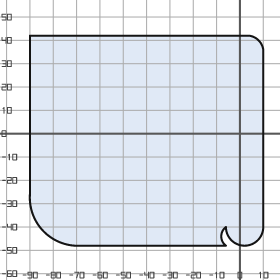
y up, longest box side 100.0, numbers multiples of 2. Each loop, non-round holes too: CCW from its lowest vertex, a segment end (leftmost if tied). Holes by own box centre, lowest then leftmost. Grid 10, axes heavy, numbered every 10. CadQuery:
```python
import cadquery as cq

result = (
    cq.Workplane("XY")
    .moveTo(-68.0, -48.0)
    .lineTo(-6.0, -48.0)
    .threePointArc((-8.0, -44.0), (-6.0, -40.0))
    .threePointArc((2.0, -48.0), (10.0, -40.0))
    .lineTo(10.0, 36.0)
    .threePointArc((8.0, 40.0), (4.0, 42.0))
    .lineTo(-90.0, 42.0)
    .lineTo(-90.0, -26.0)
    .threePointArc((-84.0, -42.0), (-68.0, -48.0))
    .close()
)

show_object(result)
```